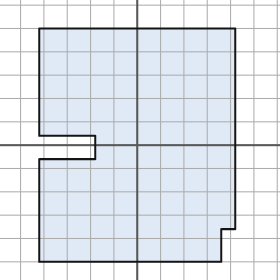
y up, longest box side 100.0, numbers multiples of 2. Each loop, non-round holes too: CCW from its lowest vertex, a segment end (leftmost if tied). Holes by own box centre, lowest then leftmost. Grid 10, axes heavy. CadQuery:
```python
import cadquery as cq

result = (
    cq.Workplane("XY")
    .moveTo(-42.0, -50.0)
    .lineTo(36.0, -50.0)
    .lineTo(36.0, -36.0)
    .lineTo(42.0, -36.0)
    .lineTo(42.0, 50.0)
    .lineTo(-42.0, 50.0)
    .lineTo(-42.0, 4.0)
    .lineTo(-18.0, 4.0)
    .lineTo(-18.0, -6.0)
    .lineTo(-42.0, -6.0)
    .close()
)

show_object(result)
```